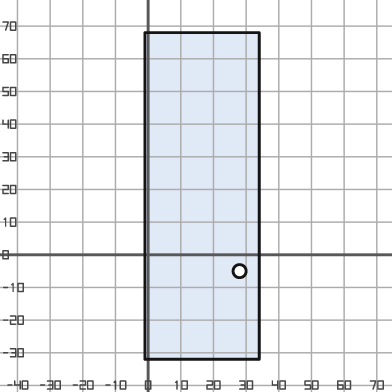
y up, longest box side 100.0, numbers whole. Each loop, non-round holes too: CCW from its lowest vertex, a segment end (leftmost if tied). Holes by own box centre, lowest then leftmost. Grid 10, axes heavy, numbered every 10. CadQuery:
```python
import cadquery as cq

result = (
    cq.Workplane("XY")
    .moveTo(-1.0, -32.0)
    .lineTo(34.0, -32.0)
    .lineTo(34.0, 68.0)
    .lineTo(-1.0, 68.0)
    .close()
    .moveTo(28.0, -5.0)
    .circle(2.0)
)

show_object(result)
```